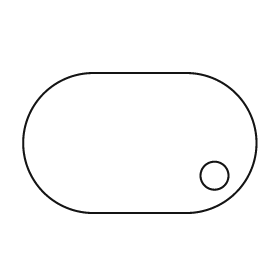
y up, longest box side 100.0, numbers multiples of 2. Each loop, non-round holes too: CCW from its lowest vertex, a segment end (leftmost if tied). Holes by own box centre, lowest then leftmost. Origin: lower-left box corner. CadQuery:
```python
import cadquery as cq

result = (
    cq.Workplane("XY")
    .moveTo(30.0, 0.0)
    .lineTo(70.0, 0.0)
    .threePointArc((100.0, 30.0), (70.0, 60.0))
    .lineTo(30.0, 60.0)
    .threePointArc((0.0, 30.0), (30.0, 0.0))
    .close()
    .moveTo(82.0, 16.0)
    .circle(6.0)
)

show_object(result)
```